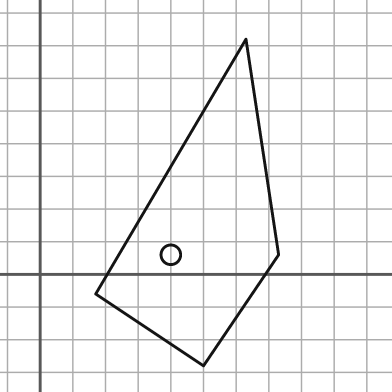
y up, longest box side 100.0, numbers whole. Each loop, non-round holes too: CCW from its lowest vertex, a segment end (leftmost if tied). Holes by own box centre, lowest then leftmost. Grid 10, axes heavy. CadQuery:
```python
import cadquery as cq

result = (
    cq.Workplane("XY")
    .moveTo(50.0, -28.0)
    .lineTo(73.0, 6.0)
    .lineTo(63.0, 72.0)
    .lineTo(17.0, -6.0)
    .close()
    .moveTo(40.0, 6.0)
    .circle(3.0)
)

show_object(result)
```